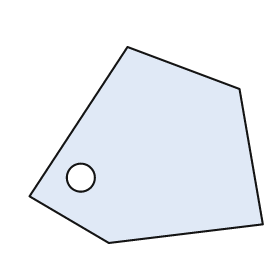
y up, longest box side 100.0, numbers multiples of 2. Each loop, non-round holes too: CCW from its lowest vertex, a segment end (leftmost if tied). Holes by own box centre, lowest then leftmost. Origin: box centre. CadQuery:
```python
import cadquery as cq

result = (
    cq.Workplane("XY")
    .moveTo(-16.0, -42.0)
    .lineTo(50.0, -34.0)
    .lineTo(40.0, 24.0)
    .lineTo(-8.0, 42.0)
    .lineTo(-50.0, -22.0)
    .close()
    .moveTo(-28.0, -14.0)
    .circle(6.0)
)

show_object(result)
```